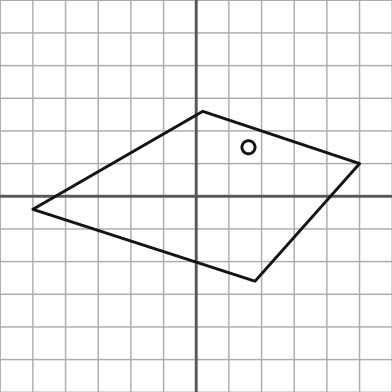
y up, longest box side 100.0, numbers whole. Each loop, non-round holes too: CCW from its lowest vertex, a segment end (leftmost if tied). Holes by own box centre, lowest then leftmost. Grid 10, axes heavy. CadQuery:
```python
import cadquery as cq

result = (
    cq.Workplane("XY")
    .moveTo(18.0, -26.0)
    .lineTo(50.0, 10.0)
    .lineTo(2.0, 26.0)
    .lineTo(-50.0, -4.0)
    .close()
    .moveTo(16.0, 15.0)
    .circle(2.0)
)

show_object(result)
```